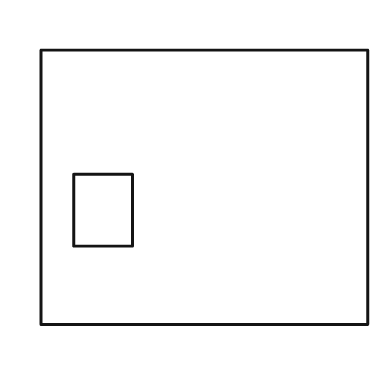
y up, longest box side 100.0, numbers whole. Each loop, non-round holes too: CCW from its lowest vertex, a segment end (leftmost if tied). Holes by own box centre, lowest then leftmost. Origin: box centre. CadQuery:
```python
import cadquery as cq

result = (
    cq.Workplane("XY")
    .moveTo(-50.0, -42.0)
    .lineTo(50.0, -42.0)
    .lineTo(50.0, 42.0)
    .lineTo(-50.0, 42.0)
    .close()
    .moveTo(-40.0, -18.0)
    .lineTo(-22.0, -18.0)
    .lineTo(-22.0, 4.0)
    .lineTo(-40.0, 4.0)
    .close()
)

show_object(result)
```